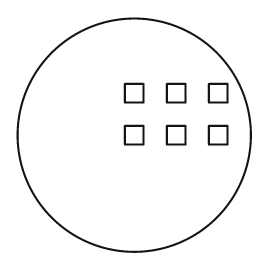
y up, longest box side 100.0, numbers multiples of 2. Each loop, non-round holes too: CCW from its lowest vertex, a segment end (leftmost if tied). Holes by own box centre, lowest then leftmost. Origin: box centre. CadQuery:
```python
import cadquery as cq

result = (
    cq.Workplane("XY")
    .moveTo(0.0, 0.0)
    .circle(50.0)
    .moveTo(-4.0, -4.0)
    .lineTo(4.0, -4.0)
    .lineTo(4.0, 4.0)
    .lineTo(-4.0, 4.0)
    .close()
    .moveTo(14.0, -4.0)
    .lineTo(22.0, -4.0)
    .lineTo(22.0, 4.0)
    .lineTo(14.0, 4.0)
    .close()
    .moveTo(32.0, -4.0)
    .lineTo(40.0, -4.0)
    .lineTo(40.0, 4.0)
    .lineTo(32.0, 4.0)
    .close()
    .moveTo(-4.0, 14.0)
    .lineTo(4.0, 14.0)
    .lineTo(4.0, 22.0)
    .lineTo(-4.0, 22.0)
    .close()
    .moveTo(14.0, 14.0)
    .lineTo(22.0, 14.0)
    .lineTo(22.0, 22.0)
    .lineTo(14.0, 22.0)
    .close()
    .moveTo(32.0, 14.0)
    .lineTo(40.0, 14.0)
    .lineTo(40.0, 22.0)
    .lineTo(32.0, 22.0)
    .close()
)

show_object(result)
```